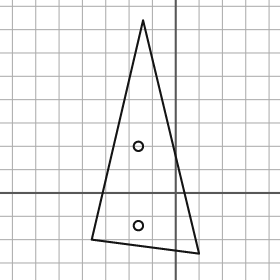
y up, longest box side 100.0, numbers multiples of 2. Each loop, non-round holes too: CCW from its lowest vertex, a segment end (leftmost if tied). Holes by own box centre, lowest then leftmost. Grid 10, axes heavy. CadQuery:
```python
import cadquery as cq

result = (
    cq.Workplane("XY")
    .moveTo(10.0, -26.0)
    .lineTo(-14.0, 74.0)
    .lineTo(-36.0, -20.0)
    .close()
    .moveTo(-16.0, -14.0)
    .circle(2.0)
    .moveTo(-16.0, 20.0)
    .circle(2.0)
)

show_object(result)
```